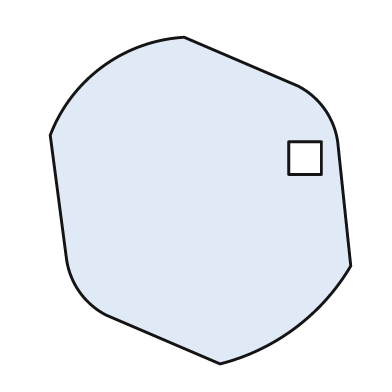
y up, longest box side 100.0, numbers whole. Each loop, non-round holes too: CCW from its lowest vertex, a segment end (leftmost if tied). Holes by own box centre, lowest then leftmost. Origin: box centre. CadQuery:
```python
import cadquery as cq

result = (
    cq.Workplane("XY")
    .moveTo(6.0, -50.0)
    .threePointArc((29.0, -39.0), (46.0, -20.0))
    .lineTo(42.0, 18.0)
    .threePointArc((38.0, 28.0), (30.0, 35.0))
    .lineTo(-5.0, 50.0)
    .threePointArc((-30.0, 41.0), (-46.0, 20.0))
    .lineTo(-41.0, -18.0)
    .threePointArc((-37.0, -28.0), (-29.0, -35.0))
    .close()
    .moveTo(27.0, 8.0)
    .lineTo(37.0, 8.0)
    .lineTo(37.0, 18.0)
    .lineTo(27.0, 18.0)
    .close()
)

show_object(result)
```